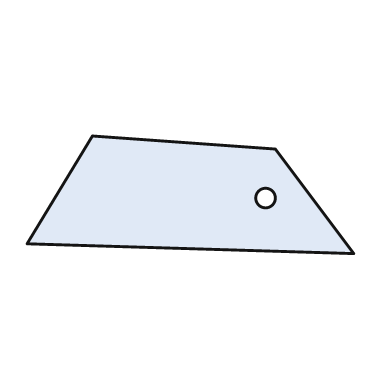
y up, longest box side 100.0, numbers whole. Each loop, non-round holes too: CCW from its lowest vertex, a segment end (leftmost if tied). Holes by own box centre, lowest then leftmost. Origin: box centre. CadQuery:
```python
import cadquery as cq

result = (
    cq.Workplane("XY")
    .moveTo(50.0, -18.0)
    .lineTo(26.0, 14.0)
    .lineTo(-30.0, 18.0)
    .lineTo(-50.0, -15.0)
    .close()
    .moveTo(23.0, -1.0)
    .circle(3.0)
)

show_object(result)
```